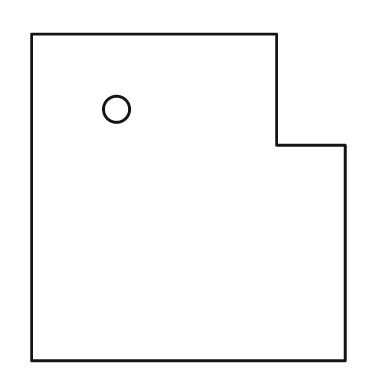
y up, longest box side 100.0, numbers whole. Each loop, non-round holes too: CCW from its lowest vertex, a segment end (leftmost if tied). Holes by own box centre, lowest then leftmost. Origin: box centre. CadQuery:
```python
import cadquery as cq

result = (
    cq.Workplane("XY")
    .moveTo(-48.0, -50.0)
    .lineTo(48.0, -50.0)
    .lineTo(48.0, 16.0)
    .lineTo(27.0, 16.0)
    .lineTo(27.0, 50.0)
    .lineTo(-48.0, 50.0)
    .close()
    .moveTo(-22.0, 27.0)
    .circle(4.0)
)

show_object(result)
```